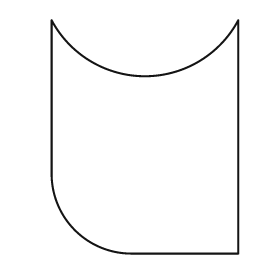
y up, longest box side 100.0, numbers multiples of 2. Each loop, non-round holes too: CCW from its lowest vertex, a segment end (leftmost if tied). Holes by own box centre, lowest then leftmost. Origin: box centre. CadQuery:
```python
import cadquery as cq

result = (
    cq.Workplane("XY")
    .moveTo(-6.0, -50.0)
    .lineTo(40.0, -50.0)
    .lineTo(40.0, 50.0)
    .threePointArc((0.0, 26.0), (-40.0, 50.0))
    .lineTo(-40.0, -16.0)
    .threePointArc((-30.0, -40.0), (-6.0, -50.0))
    .close()
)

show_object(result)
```